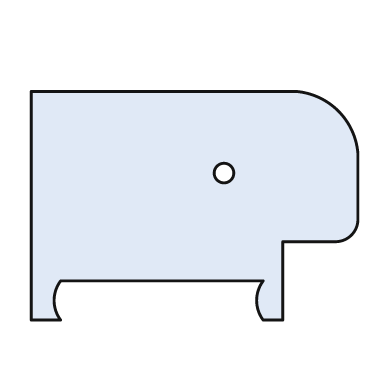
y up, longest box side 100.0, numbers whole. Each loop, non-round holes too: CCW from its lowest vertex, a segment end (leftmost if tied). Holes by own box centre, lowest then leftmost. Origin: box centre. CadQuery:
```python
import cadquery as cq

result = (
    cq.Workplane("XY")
    .moveTo(-50.0, -35.0)
    .lineTo(-41.0, -35.0)
    .threePointArc((-43.0, -29.0), (-41.0, -23.0))
    .lineTo(21.0, -23.0)
    .threePointArc((19.0, -29.0), (21.0, -35.0))
    .lineTo(27.0, -35.0)
    .lineTo(27.0, -11.0)
    .lineTo(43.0, -11.0)
    .threePointArc((48.0, -9.0), (50.0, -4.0))
    .lineTo(50.0, 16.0)
    .threePointArc((44.0, 29.0), (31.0, 35.0))
    .lineTo(-50.0, 35.0)
    .close()
    .moveTo(9.0, 10.0)
    .circle(3.0)
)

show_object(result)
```